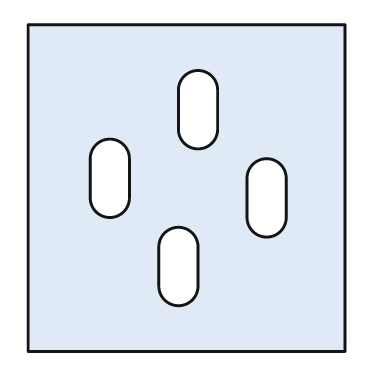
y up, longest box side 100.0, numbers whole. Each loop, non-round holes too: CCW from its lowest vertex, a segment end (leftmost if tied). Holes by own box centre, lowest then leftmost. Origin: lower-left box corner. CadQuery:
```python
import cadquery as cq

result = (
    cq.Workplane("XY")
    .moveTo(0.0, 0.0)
    .lineTo(97.0, 0.0)
    .lineTo(97.0, 100.0)
    .lineTo(0.0, 100.0)
    .close()
    .moveTo(40.0, 20.0)
    .threePointArc((46.0, 14.0), (52.0, 20.0))
    .lineTo(52.0, 32.0)
    .threePointArc((46.0, 38.0), (40.0, 32.0))
    .close()
    .moveTo(67.0, 41.0)
    .threePointArc((73.0, 35.0), (79.0, 41.0))
    .lineTo(79.0, 53.0)
    .threePointArc((73.0, 59.0), (67.0, 53.0))
    .close()
    .moveTo(19.0, 47.0)
    .threePointArc((25.0, 41.0), (31.0, 47.0))
    .lineTo(31.0, 59.0)
    .threePointArc((25.0, 65.0), (19.0, 59.0))
    .close()
    .moveTo(46.0, 68.0)
    .threePointArc((52.0, 62.0), (58.0, 68.0))
    .lineTo(58.0, 80.0)
    .threePointArc((52.0, 86.0), (46.0, 80.0))
    .close()
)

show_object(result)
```